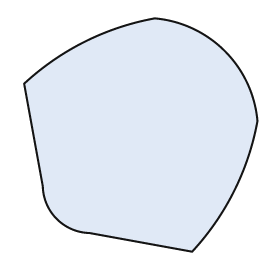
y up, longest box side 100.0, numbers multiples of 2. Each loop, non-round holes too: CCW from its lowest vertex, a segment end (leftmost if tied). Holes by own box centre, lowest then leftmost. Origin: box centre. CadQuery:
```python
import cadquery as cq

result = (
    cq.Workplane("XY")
    .moveTo(22.0, -50.0)
    .threePointArc((40.0, -24.0), (50.0, 6.0))
    .threePointArc((36.0, 36.0), (6.0, 50.0))
    .threePointArc((-24.0, 40.0), (-50.0, 22.0))
    .lineTo(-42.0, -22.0)
    .threePointArc((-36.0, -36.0), (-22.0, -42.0))
    .close()
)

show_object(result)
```